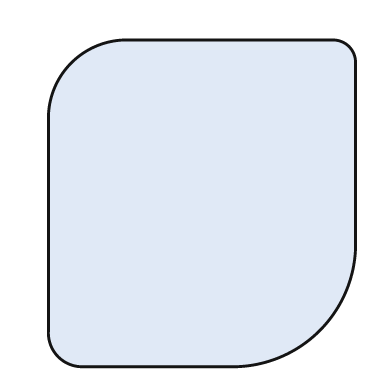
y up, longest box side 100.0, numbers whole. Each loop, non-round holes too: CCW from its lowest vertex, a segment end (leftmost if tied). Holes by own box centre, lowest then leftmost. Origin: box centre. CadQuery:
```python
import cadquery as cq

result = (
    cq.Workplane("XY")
    .moveTo(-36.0, -50.0)
    .lineTo(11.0, -50.0)
    .threePointArc((36.0, -39.0), (47.0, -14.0))
    .lineTo(47.0, 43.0)
    .threePointArc((45.0, 48.0), (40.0, 50.0))
    .lineTo(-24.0, 50.0)
    .threePointArc((-40.0, 43.0), (-47.0, 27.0))
    .lineTo(-47.0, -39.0)
    .threePointArc((-44.0, -47.0), (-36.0, -50.0))
    .close()
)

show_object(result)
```